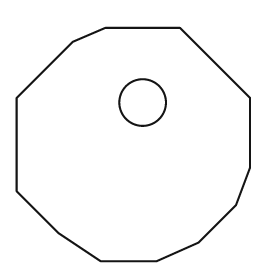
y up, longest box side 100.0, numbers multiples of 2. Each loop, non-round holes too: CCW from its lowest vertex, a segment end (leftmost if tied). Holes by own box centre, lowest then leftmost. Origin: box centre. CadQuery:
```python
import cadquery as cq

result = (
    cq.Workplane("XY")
    .moveTo(-14.0, -50.0)
    .lineTo(10.0, -50.0)
    .lineTo(28.0, -42.0)
    .lineTo(44.0, -26.0)
    .lineTo(50.0, -10.0)
    .lineTo(50.0, 20.0)
    .lineTo(20.0, 50.0)
    .lineTo(-12.0, 50.0)
    .lineTo(-26.0, 44.0)
    .lineTo(-50.0, 20.0)
    .lineTo(-50.0, -20.0)
    .lineTo(-32.0, -38.0)
    .close()
    .moveTo(4.0, 18.0)
    .circle(10.0)
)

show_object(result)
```